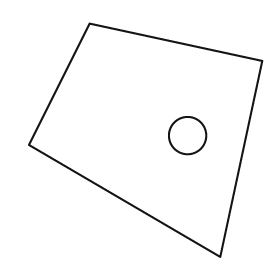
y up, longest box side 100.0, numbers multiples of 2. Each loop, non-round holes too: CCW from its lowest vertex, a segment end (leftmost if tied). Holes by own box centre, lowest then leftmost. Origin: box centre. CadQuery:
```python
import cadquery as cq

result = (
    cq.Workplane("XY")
    .moveTo(32.0, -50.0)
    .lineTo(50.0, 34.0)
    .lineTo(-24.0, 50.0)
    .lineTo(-50.0, -2.0)
    .close()
    .moveTo(18.0, 2.0)
    .circle(8.0)
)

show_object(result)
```